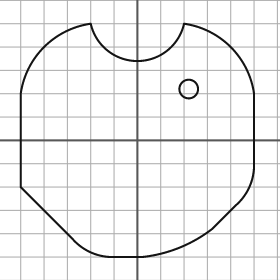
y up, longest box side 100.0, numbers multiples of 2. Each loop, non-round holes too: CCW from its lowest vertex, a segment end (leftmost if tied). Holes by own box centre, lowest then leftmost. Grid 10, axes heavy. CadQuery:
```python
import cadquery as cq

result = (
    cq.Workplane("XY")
    .moveTo(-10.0, -50.0)
    .lineTo(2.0, -50.0)
    .threePointArc((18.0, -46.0), (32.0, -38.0))
    .lineTo(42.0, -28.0)
    .threePointArc((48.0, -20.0), (50.0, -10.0))
    .lineTo(50.0, 20.0)
    .threePointArc((40.0, 40.0), (20.0, 50.0))
    .threePointArc((0.0, 34.0), (-20.0, 50.0))
    .threePointArc((-40.0, 40.0), (-50.0, 20.0))
    .lineTo(-50.0, -20.0)
    .lineTo(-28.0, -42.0)
    .threePointArc((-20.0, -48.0), (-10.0, -50.0))
    .close()
    .moveTo(22.0, 22.0)
    .circle(4.0)
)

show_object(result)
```